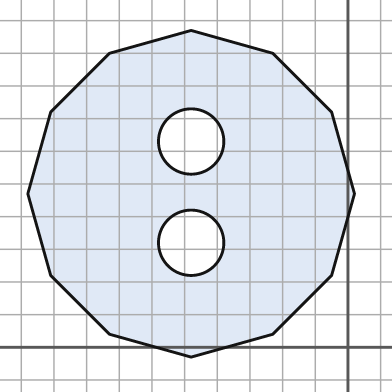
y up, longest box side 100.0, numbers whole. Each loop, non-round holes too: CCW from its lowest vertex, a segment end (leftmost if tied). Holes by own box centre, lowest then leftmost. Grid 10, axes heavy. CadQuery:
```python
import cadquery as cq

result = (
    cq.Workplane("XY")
    .moveTo(-48.0, -3.0)
    .lineTo(-23.0, 4.0)
    .lineTo(-5.0, 22.0)
    .lineTo(2.0, 47.0)
    .lineTo(-5.0, 72.0)
    .lineTo(-23.0, 90.0)
    .lineTo(-48.0, 97.0)
    .lineTo(-73.0, 90.0)
    .lineTo(-91.0, 72.0)
    .lineTo(-98.0, 47.0)
    .lineTo(-91.0, 22.0)
    .lineTo(-73.0, 4.0)
    .close()
    .moveTo(-48.0, 32.0)
    .circle(10.0)
    .moveTo(-48.0, 63.0)
    .circle(10.0)
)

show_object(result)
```